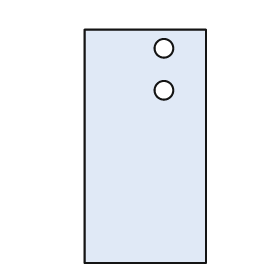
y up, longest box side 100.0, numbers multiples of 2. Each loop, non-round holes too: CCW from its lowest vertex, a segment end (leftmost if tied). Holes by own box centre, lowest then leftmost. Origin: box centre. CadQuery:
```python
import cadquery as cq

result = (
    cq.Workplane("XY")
    .moveTo(-26.0, -50.0)
    .lineTo(26.0, -50.0)
    .lineTo(26.0, 50.0)
    .lineTo(-26.0, 50.0)
    .close()
    .moveTo(8.0, 24.0)
    .circle(4.0)
    .moveTo(8.0, 42.0)
    .circle(4.0)
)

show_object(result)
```